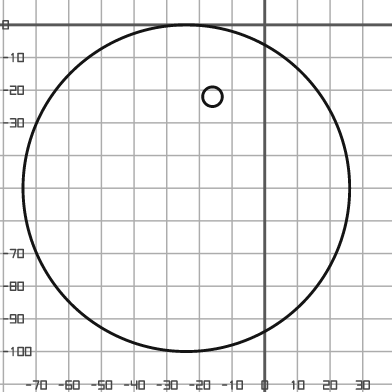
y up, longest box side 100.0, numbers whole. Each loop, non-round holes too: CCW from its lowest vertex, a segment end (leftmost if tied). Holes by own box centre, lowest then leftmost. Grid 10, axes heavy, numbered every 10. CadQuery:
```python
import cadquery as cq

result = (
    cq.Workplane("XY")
    .moveTo(-24.0, -50.0)
    .circle(50.0)
    .moveTo(-16.0, -22.0)
    .circle(3.0)
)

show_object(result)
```